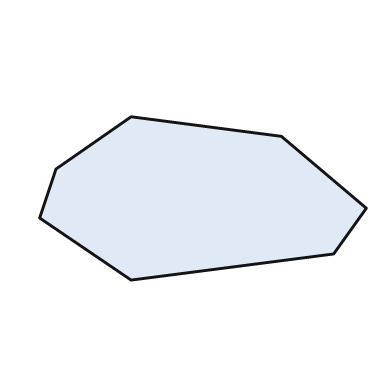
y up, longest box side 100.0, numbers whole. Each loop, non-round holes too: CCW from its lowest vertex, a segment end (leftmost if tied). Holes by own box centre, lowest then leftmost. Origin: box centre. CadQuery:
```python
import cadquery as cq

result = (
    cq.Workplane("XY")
    .moveTo(-22.0, -25.0)
    .lineTo(40.0, -17.0)
    .lineTo(50.0, -3.0)
    .lineTo(24.0, 19.0)
    .lineTo(-22.0, 25.0)
    .lineTo(-45.0, 9.0)
    .lineTo(-50.0, -6.0)
    .close()
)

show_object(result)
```